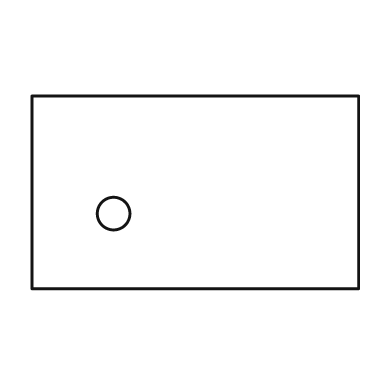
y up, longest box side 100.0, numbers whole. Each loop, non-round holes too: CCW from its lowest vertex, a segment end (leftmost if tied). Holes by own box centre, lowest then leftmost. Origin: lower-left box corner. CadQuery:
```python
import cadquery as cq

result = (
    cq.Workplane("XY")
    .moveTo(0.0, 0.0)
    .lineTo(100.0, 0.0)
    .lineTo(100.0, 59.0)
    .lineTo(0.0, 59.0)
    .close()
    .moveTo(25.0, 23.0)
    .circle(5.0)
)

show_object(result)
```